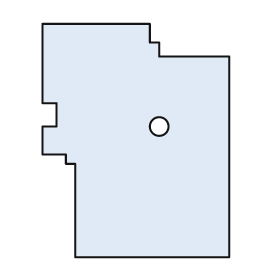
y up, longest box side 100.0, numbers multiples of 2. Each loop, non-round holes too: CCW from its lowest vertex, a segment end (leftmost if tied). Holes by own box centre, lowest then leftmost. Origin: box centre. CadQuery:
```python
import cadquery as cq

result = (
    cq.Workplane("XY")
    .moveTo(-26.0, -50.0)
    .lineTo(40.0, -50.0)
    .lineTo(40.0, 36.0)
    .lineTo(10.0, 36.0)
    .lineTo(10.0, 42.0)
    .lineTo(6.0, 42.0)
    .lineTo(6.0, 50.0)
    .lineTo(-40.0, 50.0)
    .lineTo(-40.0, 16.0)
    .lineTo(-34.0, 16.0)
    .lineTo(-34.0, 6.0)
    .lineTo(-40.0, 6.0)
    .lineTo(-40.0, -6.0)
    .lineTo(-30.0, -6.0)
    .lineTo(-30.0, -10.0)
    .lineTo(-26.0, -10.0)
    .close()
    .moveTo(10.0, 6.0)
    .circle(4.0)
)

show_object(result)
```